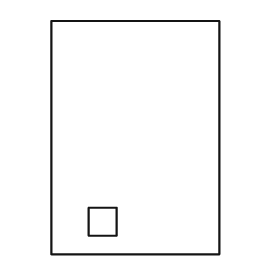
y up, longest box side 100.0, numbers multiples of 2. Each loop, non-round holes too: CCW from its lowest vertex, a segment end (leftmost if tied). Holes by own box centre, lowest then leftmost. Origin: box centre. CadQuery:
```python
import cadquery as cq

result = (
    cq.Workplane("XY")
    .moveTo(-36.0, -50.0)
    .lineTo(36.0, -50.0)
    .lineTo(36.0, 50.0)
    .lineTo(-36.0, 50.0)
    .close()
    .moveTo(-20.0, -42.0)
    .lineTo(-8.0, -42.0)
    .lineTo(-8.0, -30.0)
    .lineTo(-20.0, -30.0)
    .close()
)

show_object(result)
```